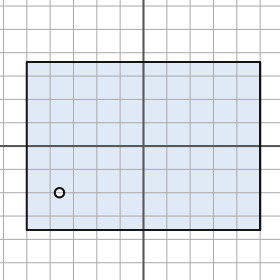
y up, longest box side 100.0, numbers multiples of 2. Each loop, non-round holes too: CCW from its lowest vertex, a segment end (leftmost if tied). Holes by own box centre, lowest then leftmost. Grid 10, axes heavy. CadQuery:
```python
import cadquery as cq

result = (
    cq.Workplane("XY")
    .moveTo(-50.0, -36.0)
    .lineTo(50.0, -36.0)
    .lineTo(50.0, 36.0)
    .lineTo(-50.0, 36.0)
    .close()
    .moveTo(-36.0, -20.0)
    .circle(2.0)
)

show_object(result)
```